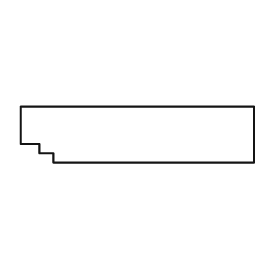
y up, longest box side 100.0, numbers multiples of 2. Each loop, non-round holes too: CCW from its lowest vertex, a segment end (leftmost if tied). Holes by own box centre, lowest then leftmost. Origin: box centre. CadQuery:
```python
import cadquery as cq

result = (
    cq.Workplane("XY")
    .moveTo(-36.0, -12.0)
    .lineTo(50.0, -12.0)
    .lineTo(50.0, 12.0)
    .lineTo(-50.0, 12.0)
    .lineTo(-50.0, -4.0)
    .lineTo(-42.0, -4.0)
    .lineTo(-42.0, -8.0)
    .lineTo(-36.0, -8.0)
    .close()
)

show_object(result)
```